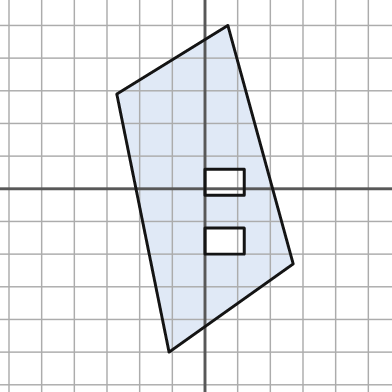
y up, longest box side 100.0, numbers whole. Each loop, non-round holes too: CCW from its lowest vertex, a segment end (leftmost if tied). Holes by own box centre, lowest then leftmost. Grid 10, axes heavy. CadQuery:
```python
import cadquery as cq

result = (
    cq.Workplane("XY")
    .moveTo(-11.0, -50.0)
    .lineTo(27.0, -23.0)
    .lineTo(7.0, 50.0)
    .lineTo(-27.0, 29.0)
    .close()
    .moveTo(0.0, -20.0)
    .lineTo(12.0, -20.0)
    .lineTo(12.0, -12.0)
    .lineTo(0.0, -12.0)
    .close()
    .moveTo(0.0, -2.0)
    .lineTo(12.0, -2.0)
    .lineTo(12.0, 6.0)
    .lineTo(0.0, 6.0)
    .close()
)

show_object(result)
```